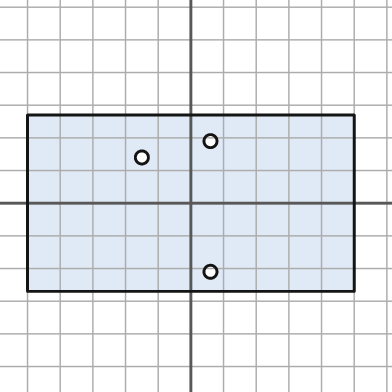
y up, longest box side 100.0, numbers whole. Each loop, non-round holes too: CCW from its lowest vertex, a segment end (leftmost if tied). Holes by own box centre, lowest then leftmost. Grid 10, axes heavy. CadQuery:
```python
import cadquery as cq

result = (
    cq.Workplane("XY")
    .moveTo(-50.0, -27.0)
    .lineTo(50.0, -27.0)
    .lineTo(50.0, 27.0)
    .lineTo(-50.0, 27.0)
    .close()
    .moveTo(6.0, -21.0)
    .circle(2.0)
    .moveTo(-15.0, 14.0)
    .circle(2.0)
    .moveTo(6.0, 19.0)
    .circle(2.0)
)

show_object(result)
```